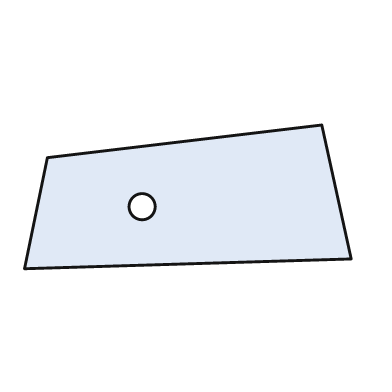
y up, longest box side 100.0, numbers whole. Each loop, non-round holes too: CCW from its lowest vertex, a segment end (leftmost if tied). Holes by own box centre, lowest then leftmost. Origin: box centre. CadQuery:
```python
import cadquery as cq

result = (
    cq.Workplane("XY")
    .moveTo(-50.0, -22.0)
    .lineTo(50.0, -19.0)
    .lineTo(41.0, 22.0)
    .lineTo(-43.0, 12.0)
    .close()
    .moveTo(-14.0, -3.0)
    .circle(4.0)
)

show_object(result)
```